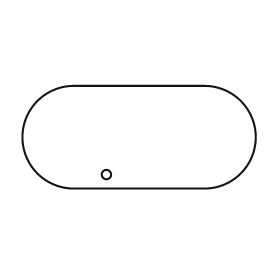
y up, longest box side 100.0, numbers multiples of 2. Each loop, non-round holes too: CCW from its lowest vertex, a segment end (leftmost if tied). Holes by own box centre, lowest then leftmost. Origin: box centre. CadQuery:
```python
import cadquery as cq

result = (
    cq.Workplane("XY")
    .moveTo(-28.0, -22.0)
    .lineTo(28.0, -22.0)
    .threePointArc((50.0, 0.0), (28.0, 22.0))
    .lineTo(-28.0, 22.0)
    .threePointArc((-50.0, 0.0), (-28.0, -22.0))
    .close()
    .moveTo(-14.0, -16.0)
    .circle(2.0)
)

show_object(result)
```